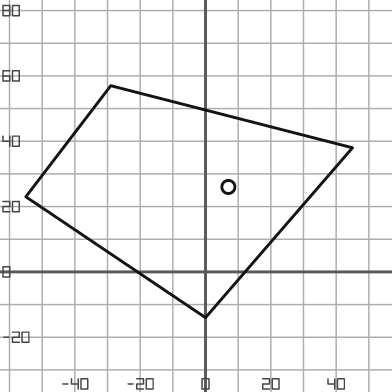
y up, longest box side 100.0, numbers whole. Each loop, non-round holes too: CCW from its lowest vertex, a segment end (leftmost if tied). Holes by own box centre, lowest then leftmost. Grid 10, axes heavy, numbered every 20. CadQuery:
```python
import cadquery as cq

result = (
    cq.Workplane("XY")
    .moveTo(0.0, -14.0)
    .lineTo(45.0, 38.0)
    .lineTo(-29.0, 57.0)
    .lineTo(-55.0, 23.0)
    .close()
    .moveTo(7.0, 26.0)
    .circle(2.0)
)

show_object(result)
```